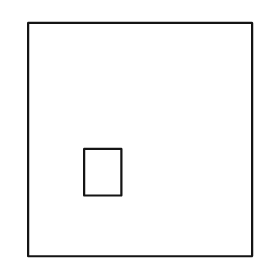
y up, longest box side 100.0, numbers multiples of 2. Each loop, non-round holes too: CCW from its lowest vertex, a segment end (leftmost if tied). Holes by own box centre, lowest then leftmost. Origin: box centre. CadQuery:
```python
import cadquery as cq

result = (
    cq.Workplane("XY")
    .moveTo(-48.0, -50.0)
    .lineTo(48.0, -50.0)
    .lineTo(48.0, 50.0)
    .lineTo(-48.0, 50.0)
    .close()
    .moveTo(-24.0, -24.0)
    .lineTo(-8.0, -24.0)
    .lineTo(-8.0, -4.0)
    .lineTo(-24.0, -4.0)
    .close()
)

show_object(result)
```